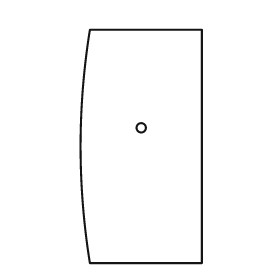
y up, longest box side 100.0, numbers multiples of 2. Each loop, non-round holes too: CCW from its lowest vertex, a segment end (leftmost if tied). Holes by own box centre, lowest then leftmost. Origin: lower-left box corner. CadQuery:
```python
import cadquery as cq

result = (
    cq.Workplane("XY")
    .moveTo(4.0, 0.0)
    .lineTo(52.0, 0.0)
    .lineTo(52.0, 100.0)
    .lineTo(4.0, 100.0)
    .threePointArc((0.0, 50.0), (4.0, 0.0))
    .close()
    .moveTo(26.0, 58.0)
    .circle(2.0)
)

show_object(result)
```